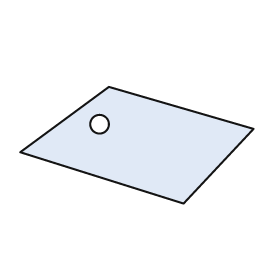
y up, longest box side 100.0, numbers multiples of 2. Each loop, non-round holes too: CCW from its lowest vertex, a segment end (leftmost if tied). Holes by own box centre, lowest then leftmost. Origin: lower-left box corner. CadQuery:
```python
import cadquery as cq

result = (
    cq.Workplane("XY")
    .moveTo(70.0, 0.0)
    .lineTo(100.0, 32.0)
    .lineTo(38.0, 50.0)
    .lineTo(0.0, 22.0)
    .close()
    .moveTo(34.0, 34.0)
    .circle(4.0)
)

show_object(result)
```